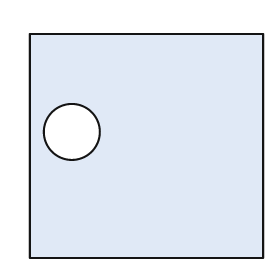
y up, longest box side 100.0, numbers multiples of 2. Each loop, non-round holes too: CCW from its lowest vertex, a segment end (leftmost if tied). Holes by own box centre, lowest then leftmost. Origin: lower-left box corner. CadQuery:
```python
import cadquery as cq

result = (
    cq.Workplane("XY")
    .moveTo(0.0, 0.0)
    .lineTo(100.0, 0.0)
    .lineTo(100.0, 96.0)
    .lineTo(0.0, 96.0)
    .close()
    .moveTo(18.0, 54.0)
    .circle(12.0)
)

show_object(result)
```